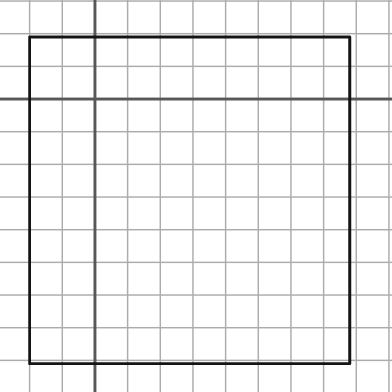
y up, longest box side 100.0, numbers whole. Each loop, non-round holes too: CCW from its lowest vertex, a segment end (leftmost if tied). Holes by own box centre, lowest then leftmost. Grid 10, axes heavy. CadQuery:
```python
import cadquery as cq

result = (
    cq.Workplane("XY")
    .moveTo(-20.0, -81.0)
    .lineTo(78.0, -81.0)
    .lineTo(78.0, 19.0)
    .lineTo(-20.0, 19.0)
    .close()
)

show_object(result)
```